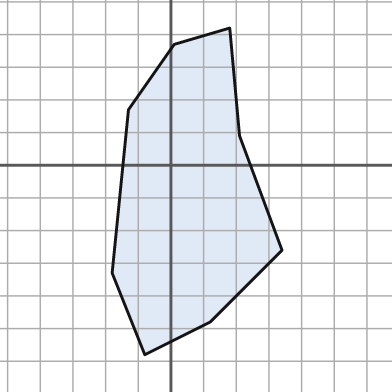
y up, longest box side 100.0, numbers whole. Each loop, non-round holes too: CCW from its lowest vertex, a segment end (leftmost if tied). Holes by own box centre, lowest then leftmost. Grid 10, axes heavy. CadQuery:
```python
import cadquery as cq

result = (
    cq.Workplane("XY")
    .moveTo(-8.0, -58.0)
    .lineTo(12.0, -48.0)
    .lineTo(34.0, -26.0)
    .lineTo(21.0, 9.0)
    .lineTo(18.0, 42.0)
    .lineTo(1.0, 37.0)
    .lineTo(-13.0, 17.0)
    .lineTo(-18.0, -33.0)
    .close()
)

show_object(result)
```